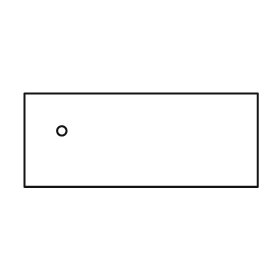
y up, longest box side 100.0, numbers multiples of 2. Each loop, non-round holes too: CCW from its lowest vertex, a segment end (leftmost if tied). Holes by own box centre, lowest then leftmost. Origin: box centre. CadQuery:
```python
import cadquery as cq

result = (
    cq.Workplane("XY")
    .moveTo(-50.0, -20.0)
    .lineTo(50.0, -20.0)
    .lineTo(50.0, 20.0)
    .lineTo(-50.0, 20.0)
    .close()
    .moveTo(-34.0, 4.0)
    .circle(2.0)
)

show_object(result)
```